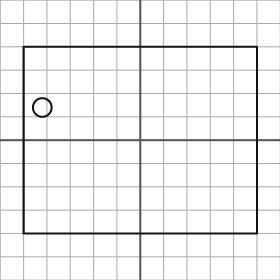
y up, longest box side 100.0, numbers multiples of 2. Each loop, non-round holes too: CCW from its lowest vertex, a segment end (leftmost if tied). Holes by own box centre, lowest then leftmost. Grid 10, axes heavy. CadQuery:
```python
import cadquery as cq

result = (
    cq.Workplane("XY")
    .moveTo(-50.0, -40.0)
    .lineTo(50.0, -40.0)
    .lineTo(50.0, 40.0)
    .lineTo(-50.0, 40.0)
    .close()
    .moveTo(-42.0, 14.0)
    .circle(4.0)
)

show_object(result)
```